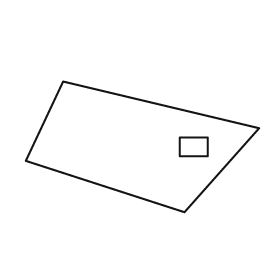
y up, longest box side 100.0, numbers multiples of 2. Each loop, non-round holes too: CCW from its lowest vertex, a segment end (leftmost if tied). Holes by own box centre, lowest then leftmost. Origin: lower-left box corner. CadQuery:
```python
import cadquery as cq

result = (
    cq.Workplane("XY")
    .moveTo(68.0, 0.0)
    .lineTo(100.0, 36.0)
    .lineTo(16.0, 56.0)
    .lineTo(0.0, 22.0)
    .close()
    .moveTo(66.0, 24.0)
    .lineTo(78.0, 24.0)
    .lineTo(78.0, 32.0)
    .lineTo(66.0, 32.0)
    .close()
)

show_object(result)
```